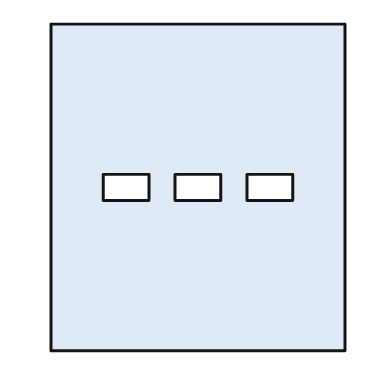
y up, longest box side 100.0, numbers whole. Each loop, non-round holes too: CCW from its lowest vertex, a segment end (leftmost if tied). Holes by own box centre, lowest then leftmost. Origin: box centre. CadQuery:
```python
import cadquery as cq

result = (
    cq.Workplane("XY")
    .moveTo(-45.0, -50.0)
    .lineTo(45.0, -50.0)
    .lineTo(45.0, 50.0)
    .lineTo(-45.0, 50.0)
    .close()
    .moveTo(-29.0, -4.0)
    .lineTo(-15.0, -4.0)
    .lineTo(-15.0, 4.0)
    .lineTo(-29.0, 4.0)
    .close()
    .moveTo(-7.0, -4.0)
    .lineTo(7.0, -4.0)
    .lineTo(7.0, 4.0)
    .lineTo(-7.0, 4.0)
    .close()
    .moveTo(15.0, -4.0)
    .lineTo(29.0, -4.0)
    .lineTo(29.0, 4.0)
    .lineTo(15.0, 4.0)
    .close()
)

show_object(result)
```